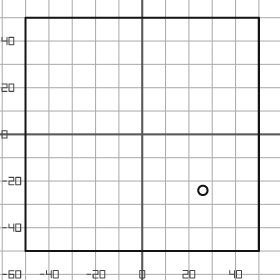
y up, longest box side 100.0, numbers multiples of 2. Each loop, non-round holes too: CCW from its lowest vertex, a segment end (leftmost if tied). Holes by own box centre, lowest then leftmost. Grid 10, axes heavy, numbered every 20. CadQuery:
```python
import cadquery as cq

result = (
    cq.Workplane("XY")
    .moveTo(-50.0, -50.0)
    .lineTo(50.0, -50.0)
    .lineTo(50.0, 50.0)
    .lineTo(-50.0, 50.0)
    .close()
    .moveTo(26.0, -24.0)
    .circle(2.0)
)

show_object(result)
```